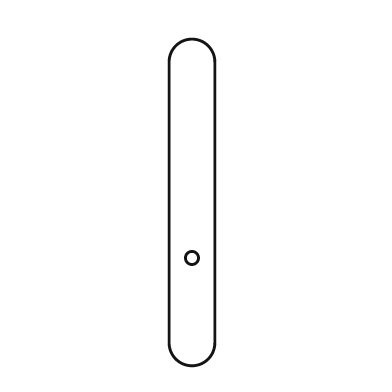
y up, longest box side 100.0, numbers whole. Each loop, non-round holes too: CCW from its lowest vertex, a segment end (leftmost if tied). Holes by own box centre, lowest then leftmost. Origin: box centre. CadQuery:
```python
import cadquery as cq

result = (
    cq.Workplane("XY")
    .moveTo(-7.0, -43.0)
    .threePointArc((0.0, -50.0), (7.0, -43.0))
    .lineTo(7.0, 43.0)
    .threePointArc((0.0, 50.0), (-7.0, 43.0))
    .close()
    .moveTo(0.0, -17.0)
    .circle(2.0)
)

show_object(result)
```